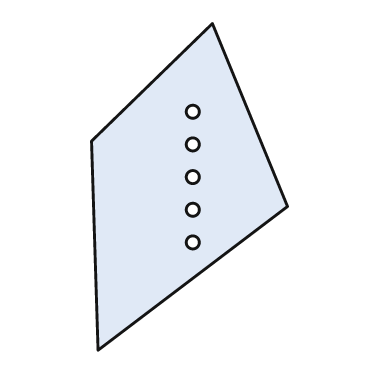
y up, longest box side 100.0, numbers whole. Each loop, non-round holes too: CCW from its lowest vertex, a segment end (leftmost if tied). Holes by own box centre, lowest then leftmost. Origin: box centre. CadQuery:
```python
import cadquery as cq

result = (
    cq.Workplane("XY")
    .moveTo(-28.0, -50.0)
    .lineTo(30.0, -6.0)
    .lineTo(7.0, 50.0)
    .lineTo(-30.0, 14.0)
    .close()
    .moveTo(1.0, -17.0)
    .circle(2.0)
    .moveTo(1.0, -7.0)
    .circle(2.0)
    .moveTo(1.0, 3.0)
    .circle(2.0)
    .moveTo(1.0, 13.0)
    .circle(2.0)
    .moveTo(1.0, 23.0)
    .circle(2.0)
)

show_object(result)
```